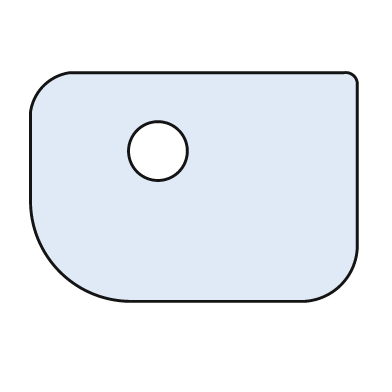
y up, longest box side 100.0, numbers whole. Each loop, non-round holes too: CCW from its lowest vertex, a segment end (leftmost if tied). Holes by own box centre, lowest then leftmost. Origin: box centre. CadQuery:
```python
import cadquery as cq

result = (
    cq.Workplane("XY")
    .moveTo(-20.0, -35.0)
    .lineTo(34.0, -35.0)
    .threePointArc((45.0, -30.0), (50.0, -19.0))
    .lineTo(50.0, 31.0)
    .threePointArc((49.0, 34.0), (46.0, 35.0))
    .lineTo(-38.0, 35.0)
    .threePointArc((-46.0, 31.0), (-50.0, 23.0))
    .lineTo(-50.0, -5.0)
    .threePointArc((-41.0, -26.0), (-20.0, -35.0))
    .close()
    .moveTo(-11.0, 11.0)
    .circle(9.0)
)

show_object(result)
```